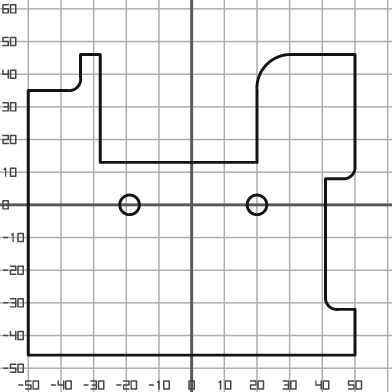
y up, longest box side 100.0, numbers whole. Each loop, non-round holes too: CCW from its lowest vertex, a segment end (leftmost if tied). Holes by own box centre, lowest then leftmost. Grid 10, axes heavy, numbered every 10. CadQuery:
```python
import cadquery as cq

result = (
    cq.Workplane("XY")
    .moveTo(-50.0, -46.0)
    .lineTo(50.0, -46.0)
    .lineTo(50.0, -32.0)
    .lineTo(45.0, -32.0)
    .threePointArc((42.0, -31.0), (41.0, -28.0))
    .lineTo(41.0, 8.0)
    .lineTo(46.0, 8.0)
    .threePointArc((49.0, 9.0), (50.0, 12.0))
    .lineTo(50.0, 46.0)
    .lineTo(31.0, 46.0)
    .threePointArc((23.0, 43.0), (20.0, 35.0))
    .lineTo(20.0, 13.0)
    .lineTo(-28.0, 13.0)
    .lineTo(-28.0, 46.0)
    .lineTo(-34.0, 46.0)
    .lineTo(-34.0, 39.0)
    .threePointArc((-35.0, 36.0), (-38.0, 35.0))
    .lineTo(-50.0, 35.0)
    .close()
    .moveTo(-19.0, 0.0)
    .circle(3.0)
    .moveTo(20.0, 0.0)
    .circle(3.0)
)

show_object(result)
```